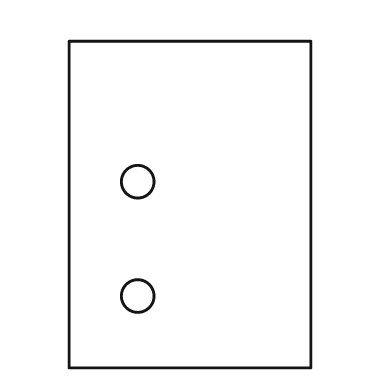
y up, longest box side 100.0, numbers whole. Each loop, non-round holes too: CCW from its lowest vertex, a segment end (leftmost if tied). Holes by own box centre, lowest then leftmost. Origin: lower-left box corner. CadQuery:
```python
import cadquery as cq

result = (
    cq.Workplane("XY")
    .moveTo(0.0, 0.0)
    .lineTo(74.0, 0.0)
    .lineTo(74.0, 100.0)
    .lineTo(0.0, 100.0)
    .close()
    .moveTo(21.0, 22.0)
    .circle(5.0)
    .moveTo(21.0, 57.0)
    .circle(5.0)
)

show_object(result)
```